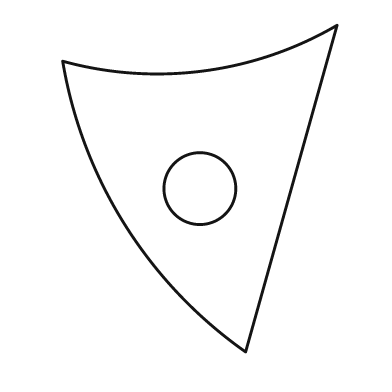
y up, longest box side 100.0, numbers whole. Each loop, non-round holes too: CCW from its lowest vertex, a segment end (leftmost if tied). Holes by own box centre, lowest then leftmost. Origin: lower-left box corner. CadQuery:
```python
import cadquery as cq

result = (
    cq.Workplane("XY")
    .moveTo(56.0, 0.0)
    .lineTo(84.0, 100.0)
    .threePointArc((43.0, 86.0), (0.0, 89.0))
    .threePointArc((19.0, 39.0), (56.0, 0.0))
    .close()
    .moveTo(42.0, 50.0)
    .circle(11.0)
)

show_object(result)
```